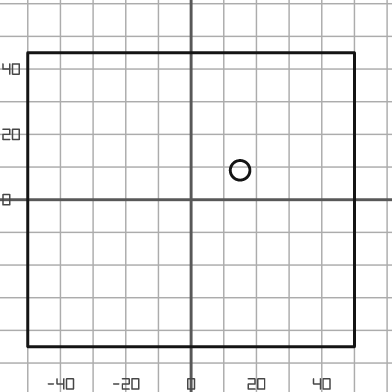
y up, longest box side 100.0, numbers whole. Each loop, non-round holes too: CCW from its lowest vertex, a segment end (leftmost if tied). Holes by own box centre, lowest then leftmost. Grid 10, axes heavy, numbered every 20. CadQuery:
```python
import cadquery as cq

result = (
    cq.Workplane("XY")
    .moveTo(-50.0, -45.0)
    .lineTo(50.0, -45.0)
    .lineTo(50.0, 45.0)
    .lineTo(-50.0, 45.0)
    .close()
    .moveTo(15.0, 9.0)
    .circle(3.0)
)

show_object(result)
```